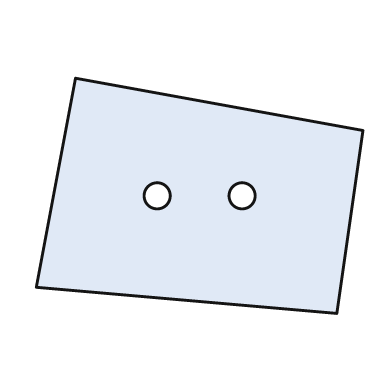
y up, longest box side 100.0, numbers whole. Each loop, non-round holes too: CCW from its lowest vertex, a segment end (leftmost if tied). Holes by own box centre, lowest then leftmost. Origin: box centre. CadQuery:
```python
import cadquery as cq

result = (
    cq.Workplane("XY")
    .moveTo(42.0, -36.0)
    .lineTo(50.0, 20.0)
    .lineTo(-38.0, 36.0)
    .lineTo(-50.0, -28.0)
    .close()
    .moveTo(-13.0, 0.0)
    .circle(4.0)
    .moveTo(13.0, 0.0)
    .circle(4.0)
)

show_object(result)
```